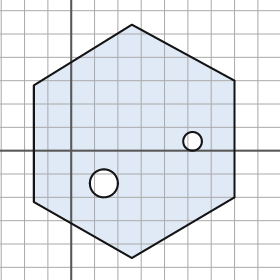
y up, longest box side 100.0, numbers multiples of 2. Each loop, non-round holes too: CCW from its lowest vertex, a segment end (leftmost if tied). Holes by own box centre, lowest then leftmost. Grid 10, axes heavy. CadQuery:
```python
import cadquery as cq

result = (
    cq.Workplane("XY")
    .moveTo(26.0, -46.0)
    .lineTo(70.0, -20.0)
    .lineTo(70.0, 30.0)
    .lineTo(26.0, 54.0)
    .lineTo(-16.0, 28.0)
    .lineTo(-16.0, -22.0)
    .close()
    .moveTo(14.0, -14.0)
    .circle(6.0)
    .moveTo(52.0, 4.0)
    .circle(4.0)
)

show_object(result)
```